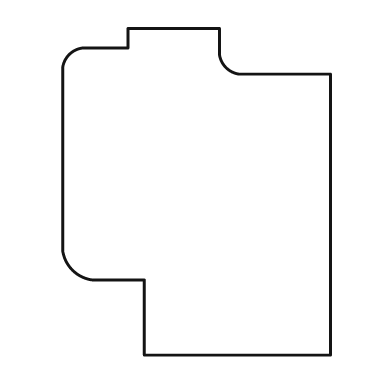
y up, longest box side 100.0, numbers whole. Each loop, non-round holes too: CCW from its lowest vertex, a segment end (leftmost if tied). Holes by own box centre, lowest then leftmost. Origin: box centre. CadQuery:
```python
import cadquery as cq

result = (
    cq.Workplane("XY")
    .moveTo(-16.0, -50.0)
    .lineTo(41.0, -50.0)
    .lineTo(41.0, 36.0)
    .lineTo(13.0, 36.0)
    .threePointArc((9.0, 38.0), (7.0, 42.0))
    .lineTo(7.0, 50.0)
    .lineTo(-21.0, 50.0)
    .lineTo(-21.0, 44.0)
    .lineTo(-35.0, 44.0)
    .threePointArc((-39.0, 42.0), (-41.0, 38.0))
    .lineTo(-41.0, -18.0)
    .threePointArc((-38.0, -24.0), (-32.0, -27.0))
    .lineTo(-16.0, -27.0)
    .close()
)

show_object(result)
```